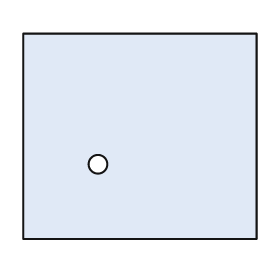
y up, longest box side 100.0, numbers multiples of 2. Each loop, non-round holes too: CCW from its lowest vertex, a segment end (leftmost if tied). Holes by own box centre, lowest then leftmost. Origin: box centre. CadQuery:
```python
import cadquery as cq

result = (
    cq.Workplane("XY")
    .moveTo(-50.0, -44.0)
    .lineTo(50.0, -44.0)
    .lineTo(50.0, 44.0)
    .lineTo(-50.0, 44.0)
    .close()
    .moveTo(-18.0, -12.0)
    .circle(4.0)
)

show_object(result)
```